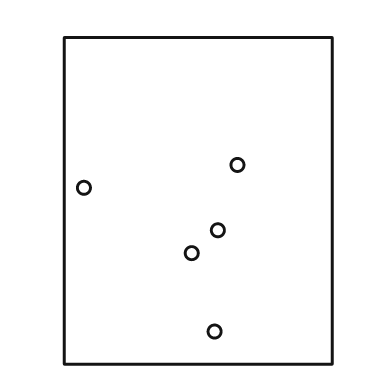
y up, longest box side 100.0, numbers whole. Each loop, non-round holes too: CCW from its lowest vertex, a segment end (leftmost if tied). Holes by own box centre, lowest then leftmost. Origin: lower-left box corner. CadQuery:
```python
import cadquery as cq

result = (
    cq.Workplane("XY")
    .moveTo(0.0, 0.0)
    .lineTo(82.0, 0.0)
    .lineTo(82.0, 100.0)
    .lineTo(0.0, 100.0)
    .close()
    .moveTo(46.0, 10.0)
    .circle(2.0)
    .moveTo(39.0, 34.0)
    .circle(2.0)
    .moveTo(47.0, 41.0)
    .circle(2.0)
    .moveTo(6.0, 54.0)
    .circle(2.0)
    .moveTo(53.0, 61.0)
    .circle(2.0)
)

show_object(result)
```